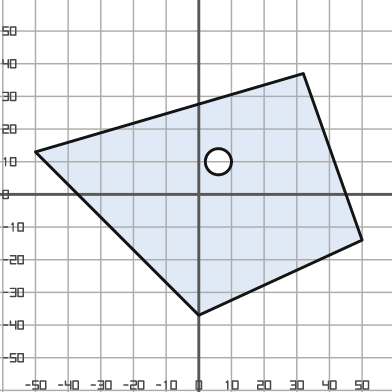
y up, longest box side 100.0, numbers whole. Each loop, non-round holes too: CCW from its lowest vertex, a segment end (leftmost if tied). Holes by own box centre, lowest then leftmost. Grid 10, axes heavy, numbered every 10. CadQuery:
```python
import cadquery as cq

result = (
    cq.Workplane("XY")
    .moveTo(0.0, -37.0)
    .lineTo(50.0, -14.0)
    .lineTo(32.0, 37.0)
    .lineTo(-50.0, 13.0)
    .close()
    .moveTo(6.0, 10.0)
    .circle(4.0)
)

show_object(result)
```